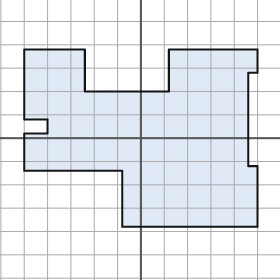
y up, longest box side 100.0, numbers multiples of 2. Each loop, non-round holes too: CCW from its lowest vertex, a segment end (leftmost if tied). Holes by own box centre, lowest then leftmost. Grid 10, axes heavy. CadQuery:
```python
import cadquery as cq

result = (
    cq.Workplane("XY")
    .moveTo(-8.0, -38.0)
    .lineTo(50.0, -38.0)
    .lineTo(50.0, -12.0)
    .lineTo(46.0, -12.0)
    .lineTo(46.0, 28.0)
    .lineTo(50.0, 28.0)
    .lineTo(50.0, 38.0)
    .lineTo(12.0, 38.0)
    .lineTo(12.0, 20.0)
    .lineTo(-24.0, 20.0)
    .lineTo(-24.0, 38.0)
    .lineTo(-50.0, 38.0)
    .lineTo(-50.0, 8.0)
    .lineTo(-40.0, 8.0)
    .lineTo(-40.0, 2.0)
    .lineTo(-50.0, 2.0)
    .lineTo(-50.0, -14.0)
    .lineTo(-8.0, -14.0)
    .close()
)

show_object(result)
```